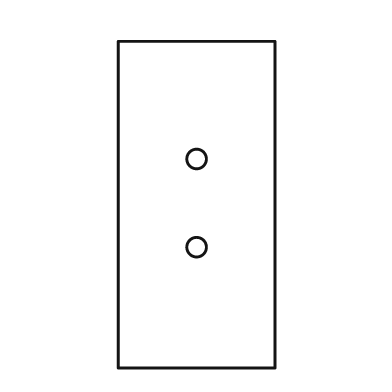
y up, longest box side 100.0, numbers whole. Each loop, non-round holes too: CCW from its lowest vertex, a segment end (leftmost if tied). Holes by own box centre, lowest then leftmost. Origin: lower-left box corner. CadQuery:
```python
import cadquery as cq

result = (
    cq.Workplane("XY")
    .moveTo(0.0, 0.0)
    .lineTo(48.0, 0.0)
    .lineTo(48.0, 100.0)
    .lineTo(0.0, 100.0)
    .close()
    .moveTo(24.0, 37.0)
    .circle(3.0)
    .moveTo(24.0, 64.0)
    .circle(3.0)
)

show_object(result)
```